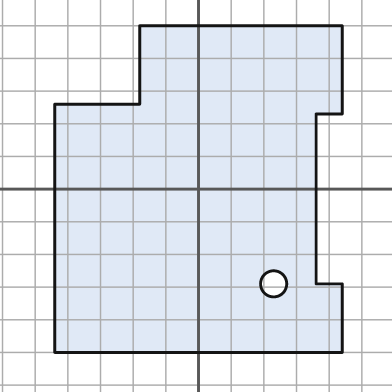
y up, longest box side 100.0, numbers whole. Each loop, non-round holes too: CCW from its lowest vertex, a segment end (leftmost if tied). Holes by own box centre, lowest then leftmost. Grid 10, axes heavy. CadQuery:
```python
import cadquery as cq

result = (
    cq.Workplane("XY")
    .moveTo(-44.0, -50.0)
    .lineTo(44.0, -50.0)
    .lineTo(44.0, -29.0)
    .lineTo(36.0, -29.0)
    .lineTo(36.0, 23.0)
    .lineTo(44.0, 23.0)
    .lineTo(44.0, 50.0)
    .lineTo(-18.0, 50.0)
    .lineTo(-18.0, 26.0)
    .lineTo(-44.0, 26.0)
    .close()
    .moveTo(23.0, -29.0)
    .circle(4.0)
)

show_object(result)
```